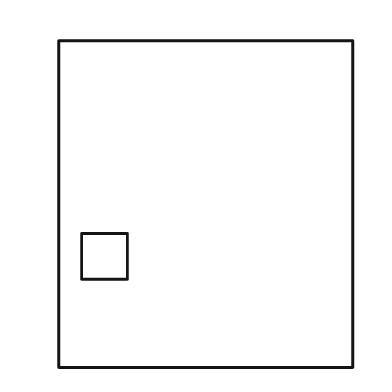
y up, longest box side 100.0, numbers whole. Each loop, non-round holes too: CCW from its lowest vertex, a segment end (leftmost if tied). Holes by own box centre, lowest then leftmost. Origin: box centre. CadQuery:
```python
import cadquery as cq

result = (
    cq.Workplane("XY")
    .moveTo(-45.0, -50.0)
    .lineTo(45.0, -50.0)
    .lineTo(45.0, 50.0)
    .lineTo(-45.0, 50.0)
    .close()
    .moveTo(-38.0, -23.0)
    .lineTo(-24.0, -23.0)
    .lineTo(-24.0, -9.0)
    .lineTo(-38.0, -9.0)
    .close()
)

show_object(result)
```